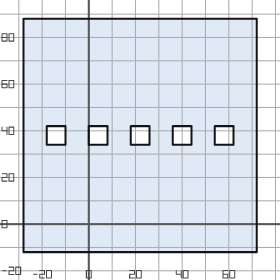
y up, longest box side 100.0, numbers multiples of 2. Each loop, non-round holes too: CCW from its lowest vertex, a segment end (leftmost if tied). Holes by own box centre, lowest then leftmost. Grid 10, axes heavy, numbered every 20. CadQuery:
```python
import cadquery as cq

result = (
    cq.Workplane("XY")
    .moveTo(-28.0, -12.0)
    .lineTo(72.0, -12.0)
    .lineTo(72.0, 88.0)
    .lineTo(-28.0, 88.0)
    .close()
    .moveTo(-18.0, 34.0)
    .lineTo(-10.0, 34.0)
    .lineTo(-10.0, 42.0)
    .lineTo(-18.0, 42.0)
    .close()
    .moveTo(0.0, 34.0)
    .lineTo(8.0, 34.0)
    .lineTo(8.0, 42.0)
    .lineTo(0.0, 42.0)
    .close()
    .moveTo(18.0, 34.0)
    .lineTo(26.0, 34.0)
    .lineTo(26.0, 42.0)
    .lineTo(18.0, 42.0)
    .close()
    .moveTo(36.0, 34.0)
    .lineTo(44.0, 34.0)
    .lineTo(44.0, 42.0)
    .lineTo(36.0, 42.0)
    .close()
    .moveTo(54.0, 34.0)
    .lineTo(62.0, 34.0)
    .lineTo(62.0, 42.0)
    .lineTo(54.0, 42.0)
    .close()
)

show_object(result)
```